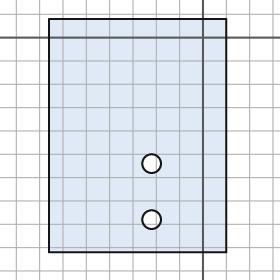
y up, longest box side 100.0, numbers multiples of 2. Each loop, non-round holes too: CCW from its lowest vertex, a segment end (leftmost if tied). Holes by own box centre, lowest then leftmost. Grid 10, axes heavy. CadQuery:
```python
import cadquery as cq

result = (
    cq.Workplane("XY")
    .moveTo(-66.0, -92.0)
    .lineTo(10.0, -92.0)
    .lineTo(10.0, 8.0)
    .lineTo(-66.0, 8.0)
    .close()
    .moveTo(-22.0, -78.0)
    .circle(4.0)
    .moveTo(-22.0, -54.0)
    .circle(4.0)
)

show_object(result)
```